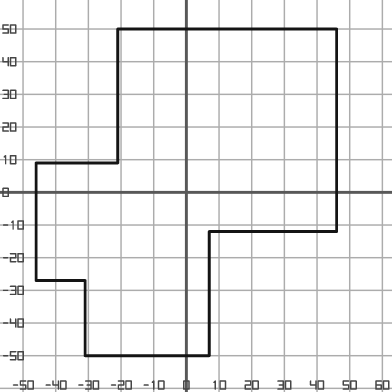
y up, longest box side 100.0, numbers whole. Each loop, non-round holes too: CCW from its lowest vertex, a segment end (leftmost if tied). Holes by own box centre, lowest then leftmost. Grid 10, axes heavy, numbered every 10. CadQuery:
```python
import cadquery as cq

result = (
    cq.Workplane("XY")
    .moveTo(-31.0, -50.0)
    .lineTo(7.0, -50.0)
    .lineTo(7.0, -12.0)
    .lineTo(46.0, -12.0)
    .lineTo(46.0, 50.0)
    .lineTo(-21.0, 50.0)
    .lineTo(-21.0, 9.0)
    .lineTo(-46.0, 9.0)
    .lineTo(-46.0, -27.0)
    .lineTo(-31.0, -27.0)
    .close()
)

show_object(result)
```